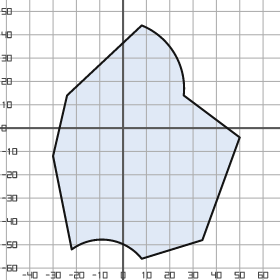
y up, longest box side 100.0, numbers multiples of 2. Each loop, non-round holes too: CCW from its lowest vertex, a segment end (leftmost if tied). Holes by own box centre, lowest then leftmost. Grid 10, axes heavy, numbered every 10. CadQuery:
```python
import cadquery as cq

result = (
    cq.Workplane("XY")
    .moveTo(8.0, -56.0)
    .lineTo(34.0, -48.0)
    .lineTo(50.0, -4.0)
    .lineTo(26.0, 14.0)
    .threePointArc((22.0, 32.0), (8.0, 44.0))
    .lineTo(-24.0, 14.0)
    .lineTo(-30.0, -12.0)
    .lineTo(-22.0, -52.0)
    .threePointArc((-6.0, -48.0), (8.0, -56.0))
    .close()
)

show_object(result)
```